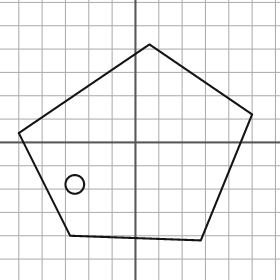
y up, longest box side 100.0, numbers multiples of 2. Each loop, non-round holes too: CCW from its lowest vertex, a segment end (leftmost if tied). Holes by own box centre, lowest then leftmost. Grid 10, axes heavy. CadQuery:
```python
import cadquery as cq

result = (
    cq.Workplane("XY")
    .moveTo(28.0, -42.0)
    .lineTo(50.0, 12.0)
    .lineTo(6.0, 42.0)
    .lineTo(-50.0, 4.0)
    .lineTo(-28.0, -40.0)
    .close()
    .moveTo(-26.0, -18.0)
    .circle(4.0)
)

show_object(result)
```